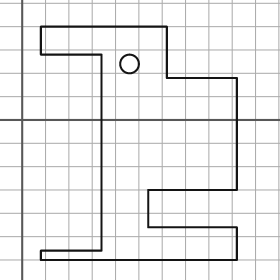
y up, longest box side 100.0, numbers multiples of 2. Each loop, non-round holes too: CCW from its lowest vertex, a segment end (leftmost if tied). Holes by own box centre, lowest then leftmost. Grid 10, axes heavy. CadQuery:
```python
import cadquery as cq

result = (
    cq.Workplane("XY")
    .moveTo(8.0, -60.0)
    .lineTo(92.0, -60.0)
    .lineTo(92.0, -46.0)
    .lineTo(54.0, -46.0)
    .lineTo(54.0, -30.0)
    .lineTo(92.0, -30.0)
    .lineTo(92.0, 18.0)
    .lineTo(62.0, 18.0)
    .lineTo(62.0, 40.0)
    .lineTo(8.0, 40.0)
    .lineTo(8.0, 28.0)
    .lineTo(34.0, 28.0)
    .lineTo(34.0, -56.0)
    .lineTo(8.0, -56.0)
    .close()
    .moveTo(46.0, 24.0)
    .circle(4.0)
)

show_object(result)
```